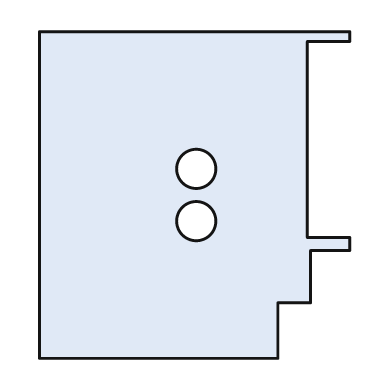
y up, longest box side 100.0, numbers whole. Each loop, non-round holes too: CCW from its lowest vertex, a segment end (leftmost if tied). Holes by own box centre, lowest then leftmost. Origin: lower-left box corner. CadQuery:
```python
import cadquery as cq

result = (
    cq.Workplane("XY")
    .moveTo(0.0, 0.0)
    .lineTo(73.0, 0.0)
    .lineTo(73.0, 17.0)
    .lineTo(83.0, 17.0)
    .lineTo(83.0, 33.0)
    .lineTo(95.0, 33.0)
    .lineTo(95.0, 37.0)
    .lineTo(82.0, 37.0)
    .lineTo(82.0, 97.0)
    .lineTo(95.0, 97.0)
    .lineTo(95.0, 100.0)
    .lineTo(0.0, 100.0)
    .close()
    .moveTo(48.0, 42.0)
    .circle(6.0)
    .moveTo(48.0, 58.0)
    .circle(6.0)
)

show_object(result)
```